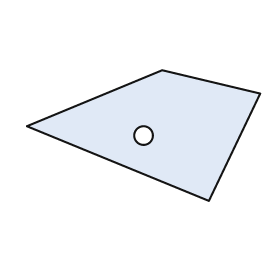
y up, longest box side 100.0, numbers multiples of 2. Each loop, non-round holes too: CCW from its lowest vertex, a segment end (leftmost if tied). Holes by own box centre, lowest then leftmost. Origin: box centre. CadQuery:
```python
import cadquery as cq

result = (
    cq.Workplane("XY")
    .moveTo(28.0, -28.0)
    .lineTo(50.0, 18.0)
    .lineTo(8.0, 28.0)
    .lineTo(-50.0, 4.0)
    .close()
    .moveTo(0.0, 0.0)
    .circle(4.0)
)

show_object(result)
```